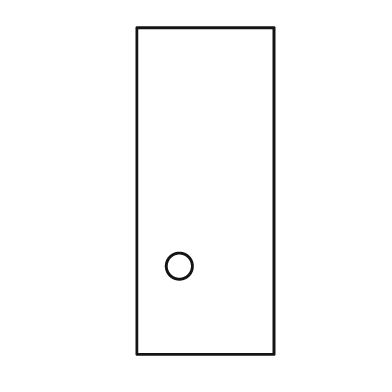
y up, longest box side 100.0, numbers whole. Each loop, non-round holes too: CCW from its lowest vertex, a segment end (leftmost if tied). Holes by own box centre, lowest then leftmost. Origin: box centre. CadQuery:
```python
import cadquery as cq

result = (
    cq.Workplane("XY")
    .moveTo(-21.0, -50.0)
    .lineTo(21.0, -50.0)
    .lineTo(21.0, 50.0)
    .lineTo(-21.0, 50.0)
    .close()
    .moveTo(-8.0, -23.0)
    .circle(4.0)
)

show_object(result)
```